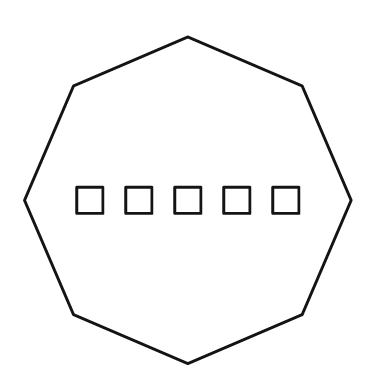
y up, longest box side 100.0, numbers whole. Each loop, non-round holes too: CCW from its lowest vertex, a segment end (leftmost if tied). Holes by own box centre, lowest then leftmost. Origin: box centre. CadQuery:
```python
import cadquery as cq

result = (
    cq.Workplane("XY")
    .moveTo(0.0, -50.0)
    .lineTo(35.0, -35.0)
    .lineTo(50.0, 0.0)
    .lineTo(35.0, 35.0)
    .lineTo(0.0, 50.0)
    .lineTo(-35.0, 35.0)
    .lineTo(-50.0, 0.0)
    .lineTo(-35.0, -35.0)
    .close()
    .moveTo(-34.0, -4.0)
    .lineTo(-26.0, -4.0)
    .lineTo(-26.0, 4.0)
    .lineTo(-34.0, 4.0)
    .close()
    .moveTo(-19.0, -4.0)
    .lineTo(-11.0, -4.0)
    .lineTo(-11.0, 4.0)
    .lineTo(-19.0, 4.0)
    .close()
    .moveTo(-4.0, -4.0)
    .lineTo(4.0, -4.0)
    .lineTo(4.0, 4.0)
    .lineTo(-4.0, 4.0)
    .close()
    .moveTo(11.0, -4.0)
    .lineTo(19.0, -4.0)
    .lineTo(19.0, 4.0)
    .lineTo(11.0, 4.0)
    .close()
    .moveTo(26.0, -4.0)
    .lineTo(34.0, -4.0)
    .lineTo(34.0, 4.0)
    .lineTo(26.0, 4.0)
    .close()
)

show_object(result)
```